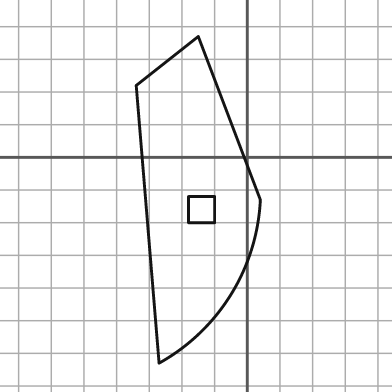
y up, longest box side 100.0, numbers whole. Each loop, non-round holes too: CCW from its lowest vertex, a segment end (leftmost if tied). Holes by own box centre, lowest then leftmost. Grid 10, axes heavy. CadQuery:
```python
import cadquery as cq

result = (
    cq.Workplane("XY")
    .moveTo(-27.0, -63.0)
    .threePointArc((-5.0, -42.0), (4.0, -13.0))
    .lineTo(-15.0, 37.0)
    .lineTo(-34.0, 22.0)
    .close()
    .moveTo(-18.0, -20.0)
    .lineTo(-10.0, -20.0)
    .lineTo(-10.0, -12.0)
    .lineTo(-18.0, -12.0)
    .close()
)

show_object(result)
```